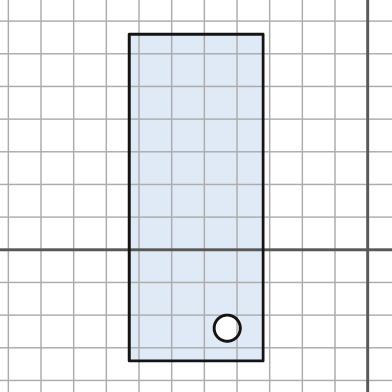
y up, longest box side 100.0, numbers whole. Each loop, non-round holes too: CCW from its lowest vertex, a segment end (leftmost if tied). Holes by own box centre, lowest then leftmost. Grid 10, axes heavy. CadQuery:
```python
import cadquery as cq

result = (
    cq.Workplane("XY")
    .moveTo(-73.0, -34.0)
    .lineTo(-32.0, -34.0)
    .lineTo(-32.0, 66.0)
    .lineTo(-73.0, 66.0)
    .close()
    .moveTo(-43.0, -24.0)
    .circle(4.0)
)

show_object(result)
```